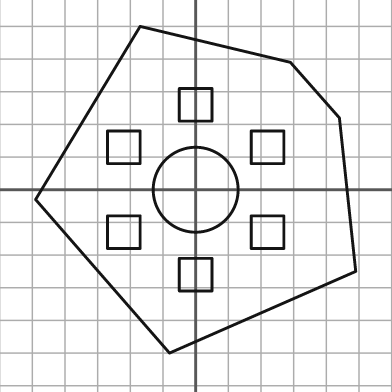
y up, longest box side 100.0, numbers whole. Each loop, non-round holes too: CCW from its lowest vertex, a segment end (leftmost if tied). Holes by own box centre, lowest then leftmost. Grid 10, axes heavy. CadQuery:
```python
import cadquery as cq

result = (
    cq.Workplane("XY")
    .moveTo(-8.0, -50.0)
    .lineTo(49.0, -25.0)
    .lineTo(44.0, 22.0)
    .lineTo(29.0, 39.0)
    .lineTo(-17.0, 50.0)
    .lineTo(-49.0, -3.0)
    .close()
    .moveTo(-5.0, -31.0)
    .lineTo(5.0, -31.0)
    .lineTo(5.0, -21.0)
    .lineTo(-5.0, -21.0)
    .close()
    .moveTo(-27.0, -18.0)
    .lineTo(-17.0, -18.0)
    .lineTo(-17.0, -8.0)
    .lineTo(-27.0, -8.0)
    .close()
    .moveTo(17.0, -18.0)
    .lineTo(27.0, -18.0)
    .lineTo(27.0, -8.0)
    .lineTo(17.0, -8.0)
    .close()
    .moveTo(0.0, 0.0)
    .circle(13.0)
    .moveTo(-27.0, 8.0)
    .lineTo(-17.0, 8.0)
    .lineTo(-17.0, 18.0)
    .lineTo(-27.0, 18.0)
    .close()
    .moveTo(17.0, 8.0)
    .lineTo(27.0, 8.0)
    .lineTo(27.0, 18.0)
    .lineTo(17.0, 18.0)
    .close()
    .moveTo(-5.0, 21.0)
    .lineTo(5.0, 21.0)
    .lineTo(5.0, 31.0)
    .lineTo(-5.0, 31.0)
    .close()
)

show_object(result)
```